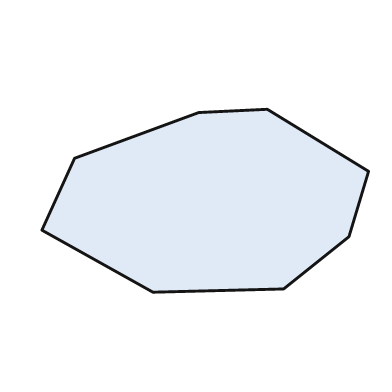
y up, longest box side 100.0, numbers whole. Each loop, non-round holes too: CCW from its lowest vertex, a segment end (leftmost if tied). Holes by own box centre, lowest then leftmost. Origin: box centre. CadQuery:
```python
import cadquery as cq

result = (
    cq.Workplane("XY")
    .moveTo(-16.0, -28.0)
    .lineTo(24.0, -27.0)
    .lineTo(44.0, -11.0)
    .lineTo(50.0, 9.0)
    .lineTo(19.0, 28.0)
    .lineTo(-2.0, 27.0)
    .lineTo(-40.0, 13.0)
    .lineTo(-50.0, -9.0)
    .close()
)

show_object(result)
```